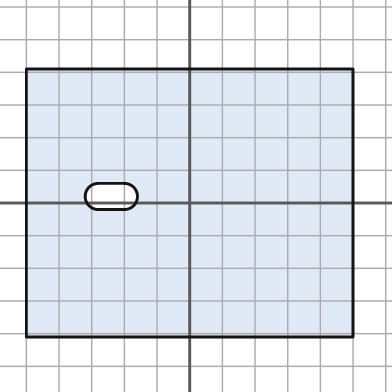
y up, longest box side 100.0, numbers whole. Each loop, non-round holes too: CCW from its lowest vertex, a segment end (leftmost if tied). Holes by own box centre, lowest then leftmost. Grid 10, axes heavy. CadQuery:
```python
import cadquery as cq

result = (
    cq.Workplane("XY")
    .moveTo(-50.0, -41.0)
    .lineTo(50.0, -41.0)
    .lineTo(50.0, 41.0)
    .lineTo(-50.0, 41.0)
    .close()
    .moveTo(-28.0, -2.0)
    .lineTo(-20.0, -2.0)
    .threePointArc((-16.0, 2.0), (-20.0, 6.0))
    .lineTo(-28.0, 6.0)
    .threePointArc((-32.0, 2.0), (-28.0, -2.0))
    .close()
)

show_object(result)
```